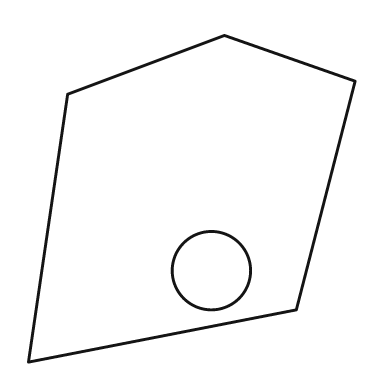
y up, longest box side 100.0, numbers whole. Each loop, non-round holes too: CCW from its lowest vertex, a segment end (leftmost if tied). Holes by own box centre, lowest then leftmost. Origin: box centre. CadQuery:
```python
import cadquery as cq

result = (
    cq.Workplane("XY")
    .moveTo(-50.0, -50.0)
    .lineTo(32.0, -34.0)
    .lineTo(50.0, 36.0)
    .lineTo(10.0, 50.0)
    .lineTo(-38.0, 32.0)
    .close()
    .moveTo(6.0, -22.0)
    .circle(12.0)
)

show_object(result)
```